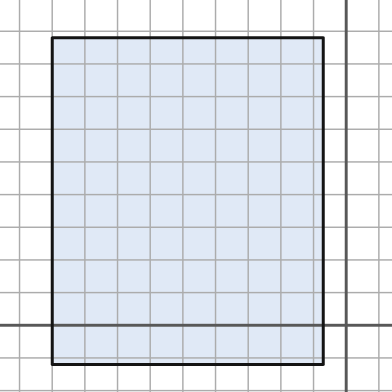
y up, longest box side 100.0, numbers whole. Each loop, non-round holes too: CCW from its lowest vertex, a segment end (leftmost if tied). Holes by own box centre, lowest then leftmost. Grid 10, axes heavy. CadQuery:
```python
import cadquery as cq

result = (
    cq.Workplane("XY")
    .moveTo(-90.0, -12.0)
    .lineTo(-7.0, -12.0)
    .lineTo(-7.0, 88.0)
    .lineTo(-90.0, 88.0)
    .close()
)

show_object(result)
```